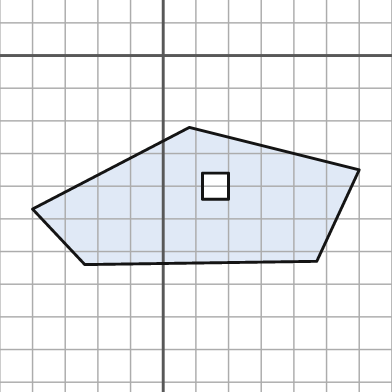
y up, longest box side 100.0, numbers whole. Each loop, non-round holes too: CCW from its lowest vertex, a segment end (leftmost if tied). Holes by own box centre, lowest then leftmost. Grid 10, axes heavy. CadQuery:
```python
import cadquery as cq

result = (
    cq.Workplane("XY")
    .moveTo(-24.0, -64.0)
    .lineTo(47.0, -63.0)
    .lineTo(60.0, -35.0)
    .lineTo(8.0, -22.0)
    .lineTo(-40.0, -47.0)
    .close()
    .moveTo(12.0, -44.0)
    .lineTo(20.0, -44.0)
    .lineTo(20.0, -36.0)
    .lineTo(12.0, -36.0)
    .close()
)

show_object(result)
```